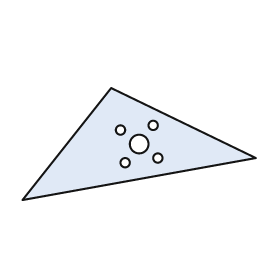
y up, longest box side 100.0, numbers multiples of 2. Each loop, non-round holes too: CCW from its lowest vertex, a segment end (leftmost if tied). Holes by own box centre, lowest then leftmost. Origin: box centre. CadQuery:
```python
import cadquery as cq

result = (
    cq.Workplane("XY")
    .moveTo(-50.0, -24.0)
    .lineTo(50.0, -6.0)
    .lineTo(-12.0, 24.0)
    .close()
    .moveTo(-6.0, -8.0)
    .circle(2.0)
    .moveTo(8.0, -6.0)
    .circle(2.0)
    .moveTo(0.0, 0.0)
    .circle(4.0)
    .moveTo(-8.0, 6.0)
    .circle(2.0)
    .moveTo(6.0, 8.0)
    .circle(2.0)
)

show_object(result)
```